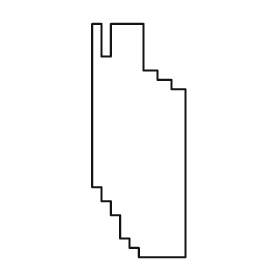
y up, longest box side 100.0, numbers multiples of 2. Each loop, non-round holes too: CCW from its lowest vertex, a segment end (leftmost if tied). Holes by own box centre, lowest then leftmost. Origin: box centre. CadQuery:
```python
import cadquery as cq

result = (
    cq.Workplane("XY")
    .moveTo(0.0, -50.0)
    .lineTo(20.0, -50.0)
    .lineTo(20.0, 22.0)
    .lineTo(14.0, 22.0)
    .lineTo(14.0, 26.0)
    .lineTo(8.0, 26.0)
    .lineTo(8.0, 30.0)
    .lineTo(2.0, 30.0)
    .lineTo(2.0, 50.0)
    .lineTo(-12.0, 50.0)
    .lineTo(-12.0, 36.0)
    .lineTo(-16.0, 36.0)
    .lineTo(-16.0, 50.0)
    .lineTo(-20.0, 50.0)
    .lineTo(-20.0, -20.0)
    .lineTo(-16.0, -20.0)
    .lineTo(-16.0, -26.0)
    .lineTo(-12.0, -26.0)
    .lineTo(-12.0, -32.0)
    .lineTo(-8.0, -32.0)
    .lineTo(-8.0, -42.0)
    .lineTo(-4.0, -42.0)
    .lineTo(-4.0, -46.0)
    .lineTo(0.0, -46.0)
    .close()
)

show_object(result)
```